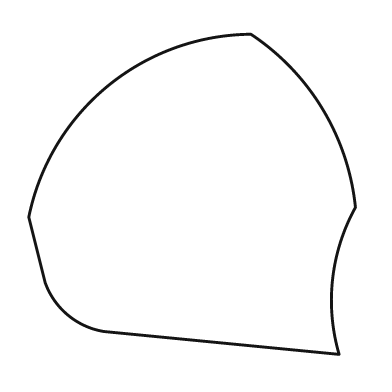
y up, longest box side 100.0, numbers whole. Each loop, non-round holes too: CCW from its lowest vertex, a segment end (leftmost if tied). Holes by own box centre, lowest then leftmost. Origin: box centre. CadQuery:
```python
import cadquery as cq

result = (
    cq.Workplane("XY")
    .moveTo(45.0, -49.0)
    .threePointArc((43.0, -26.0), (50.0, -4.0))
    .threePointArc((40.0, 26.0), (18.0, 49.0))
    .threePointArc((-26.0, 33.0), (-50.0, -7.0))
    .lineTo(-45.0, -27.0)
    .threePointArc((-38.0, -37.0), (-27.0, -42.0))
    .close()
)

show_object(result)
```